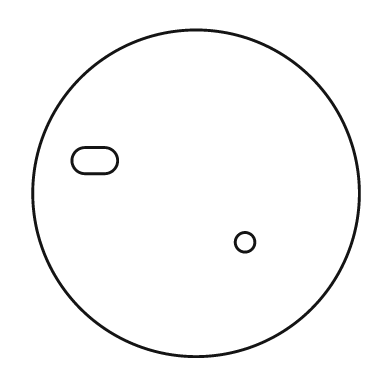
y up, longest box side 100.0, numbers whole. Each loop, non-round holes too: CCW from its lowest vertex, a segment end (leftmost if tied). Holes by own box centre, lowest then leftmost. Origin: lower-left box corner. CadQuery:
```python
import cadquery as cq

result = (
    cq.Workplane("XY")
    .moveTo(50.0, 50.0)
    .circle(50.0)
    .moveTo(65.0, 35.0)
    .circle(3.0)
    .moveTo(16.0, 56.0)
    .lineTo(22.0, 56.0)
    .threePointArc((26.0, 60.0), (22.0, 64.0))
    .lineTo(16.0, 64.0)
    .threePointArc((12.0, 60.0), (16.0, 56.0))
    .close()
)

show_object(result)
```